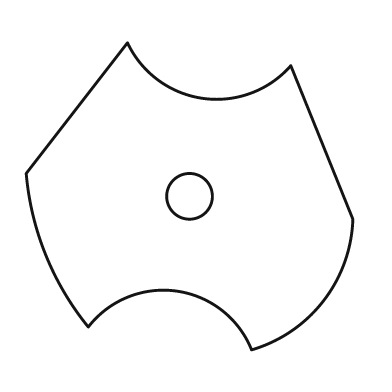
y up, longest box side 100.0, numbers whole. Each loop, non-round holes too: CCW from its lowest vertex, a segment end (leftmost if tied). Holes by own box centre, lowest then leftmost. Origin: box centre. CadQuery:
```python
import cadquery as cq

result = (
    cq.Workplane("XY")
    .moveTo(19.0, -47.0)
    .threePointArc((41.0, -32.0), (50.0, -7.0))
    .lineTo(31.0, 40.0)
    .threePointArc((4.0, 30.0), (-19.0, 47.0))
    .lineTo(-50.0, 7.0)
    .threePointArc((-44.0, -18.0), (-31.0, -40.0))
    .threePointArc((-4.0, -29.0), (19.0, -47.0))
    .close()
    .moveTo(0.0, 0.0)
    .circle(7.0)
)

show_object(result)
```